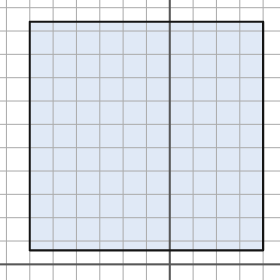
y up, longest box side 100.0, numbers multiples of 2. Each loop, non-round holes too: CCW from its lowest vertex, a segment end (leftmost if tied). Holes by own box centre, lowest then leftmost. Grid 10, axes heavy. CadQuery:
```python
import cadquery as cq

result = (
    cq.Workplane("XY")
    .moveTo(-60.0, 6.0)
    .lineTo(40.0, 6.0)
    .lineTo(40.0, 104.0)
    .lineTo(-60.0, 104.0)
    .close()
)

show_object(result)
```